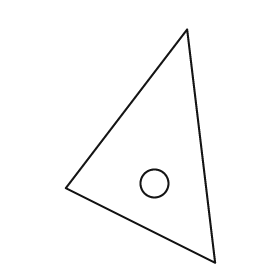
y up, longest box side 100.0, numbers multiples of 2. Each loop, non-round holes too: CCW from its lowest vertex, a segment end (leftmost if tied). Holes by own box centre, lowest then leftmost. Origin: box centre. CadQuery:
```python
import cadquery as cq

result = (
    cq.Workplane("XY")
    .moveTo(32.0, -50.0)
    .lineTo(20.0, 50.0)
    .lineTo(-32.0, -18.0)
    .close()
    .moveTo(6.0, -16.0)
    .circle(6.0)
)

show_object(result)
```